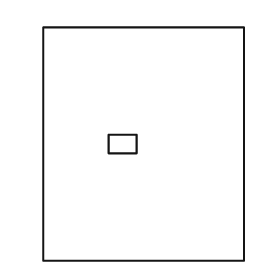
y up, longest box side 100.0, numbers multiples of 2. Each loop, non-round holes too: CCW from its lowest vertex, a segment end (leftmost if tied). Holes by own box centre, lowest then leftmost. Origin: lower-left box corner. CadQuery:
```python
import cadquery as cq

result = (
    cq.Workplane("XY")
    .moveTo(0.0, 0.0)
    .lineTo(86.0, 0.0)
    .lineTo(86.0, 100.0)
    .lineTo(0.0, 100.0)
    .close()
    .moveTo(28.0, 46.0)
    .lineTo(40.0, 46.0)
    .lineTo(40.0, 54.0)
    .lineTo(28.0, 54.0)
    .close()
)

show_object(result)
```